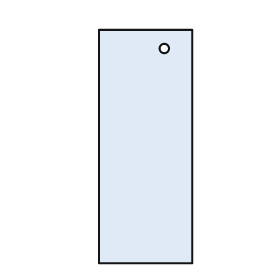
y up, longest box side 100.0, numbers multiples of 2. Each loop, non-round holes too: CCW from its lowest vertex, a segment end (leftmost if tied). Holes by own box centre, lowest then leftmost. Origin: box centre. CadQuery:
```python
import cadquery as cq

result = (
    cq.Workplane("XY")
    .moveTo(-20.0, -50.0)
    .lineTo(20.0, -50.0)
    .lineTo(20.0, 50.0)
    .lineTo(-20.0, 50.0)
    .close()
    .moveTo(8.0, 42.0)
    .circle(2.0)
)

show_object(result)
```